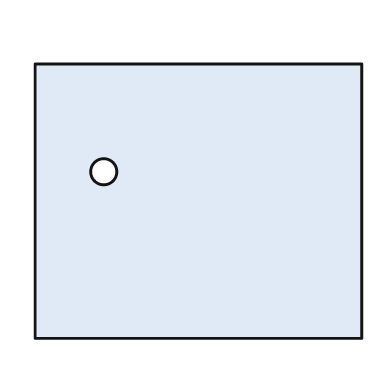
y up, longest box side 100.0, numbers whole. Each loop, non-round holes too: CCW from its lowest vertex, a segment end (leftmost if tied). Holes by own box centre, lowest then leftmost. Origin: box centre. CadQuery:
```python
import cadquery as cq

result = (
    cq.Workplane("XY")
    .moveTo(-50.0, -42.0)
    .lineTo(50.0, -42.0)
    .lineTo(50.0, 42.0)
    .lineTo(-50.0, 42.0)
    .close()
    .moveTo(-29.0, 9.0)
    .circle(4.0)
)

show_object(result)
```